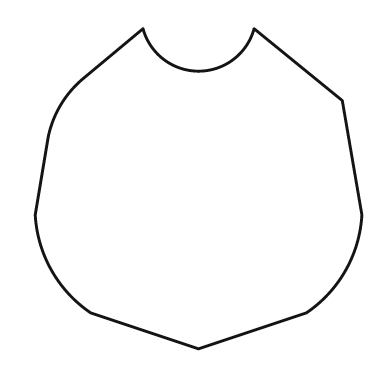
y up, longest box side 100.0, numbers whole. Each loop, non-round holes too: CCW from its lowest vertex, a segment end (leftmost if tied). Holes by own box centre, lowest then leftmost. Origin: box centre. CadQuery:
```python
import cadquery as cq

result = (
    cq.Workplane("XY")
    .moveTo(0.0, -49.0)
    .lineTo(33.0, -38.0)
    .threePointArc((45.0, -25.0), (50.0, -8.0))
    .lineTo(44.0, 27.0)
    .lineTo(17.0, 49.0)
    .threePointArc((0.0, 36.0), (-17.0, 49.0))
    .lineTo(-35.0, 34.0)
    .threePointArc((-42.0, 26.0), (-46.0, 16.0))
    .lineTo(-50.0, -8.0)
    .threePointArc((-45.0, -25.0), (-33.0, -38.0))
    .close()
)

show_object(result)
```